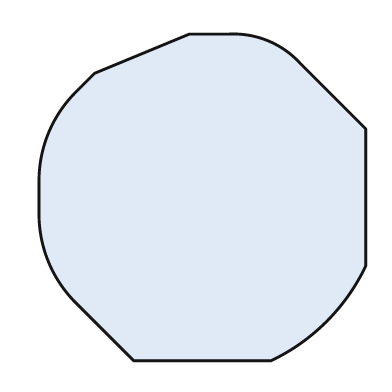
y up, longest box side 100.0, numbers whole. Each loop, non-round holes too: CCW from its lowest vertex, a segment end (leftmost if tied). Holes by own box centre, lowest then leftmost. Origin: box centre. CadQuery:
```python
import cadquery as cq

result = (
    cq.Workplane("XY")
    .moveTo(-21.0, -50.0)
    .lineTo(21.0, -50.0)
    .threePointArc((38.0, -38.0), (50.0, -21.0))
    .lineTo(50.0, 21.0)
    .lineTo(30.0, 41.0)
    .threePointArc((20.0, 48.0), (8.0, 50.0))
    .lineTo(-4.0, 50.0)
    .lineTo(-33.0, 38.0)
    .lineTo(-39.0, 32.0)
    .threePointArc((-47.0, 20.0), (-50.0, 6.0))
    .lineTo(-50.0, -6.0)
    .threePointArc((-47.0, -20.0), (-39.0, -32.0))
    .close()
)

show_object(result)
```